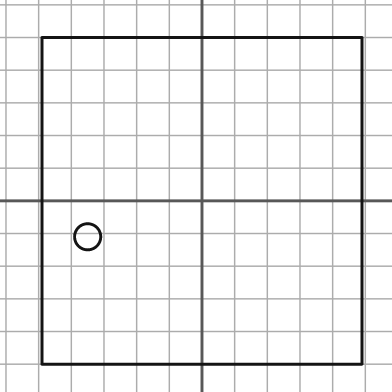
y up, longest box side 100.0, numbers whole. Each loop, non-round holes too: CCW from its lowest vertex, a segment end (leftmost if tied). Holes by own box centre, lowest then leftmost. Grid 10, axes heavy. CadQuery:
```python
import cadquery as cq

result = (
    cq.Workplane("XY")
    .moveTo(-49.0, -50.0)
    .lineTo(49.0, -50.0)
    .lineTo(49.0, 50.0)
    .lineTo(-49.0, 50.0)
    .close()
    .moveTo(-35.0, -11.0)
    .circle(4.0)
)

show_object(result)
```